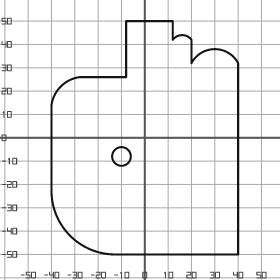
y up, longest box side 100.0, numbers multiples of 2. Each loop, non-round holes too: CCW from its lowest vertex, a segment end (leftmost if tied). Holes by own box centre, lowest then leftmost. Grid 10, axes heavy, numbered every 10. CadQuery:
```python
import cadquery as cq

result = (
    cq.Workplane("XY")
    .moveTo(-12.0, -50.0)
    .lineTo(40.0, -50.0)
    .lineTo(40.0, 32.0)
    .threePointArc((30.0, 38.0), (20.0, 32.0))
    .lineTo(20.0, 42.0)
    .threePointArc((16.0, 44.0), (12.0, 42.0))
    .lineTo(12.0, 50.0)
    .lineTo(-8.0, 50.0)
    .lineTo(-8.0, 26.0)
    .lineTo(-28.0, 26.0)
    .threePointArc((-36.0, 22.0), (-40.0, 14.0))
    .lineTo(-40.0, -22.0)
    .threePointArc((-32.0, -42.0), (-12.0, -50.0))
    .close()
    .moveTo(-10.0, -8.0)
    .circle(4.0)
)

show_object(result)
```